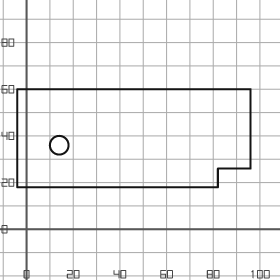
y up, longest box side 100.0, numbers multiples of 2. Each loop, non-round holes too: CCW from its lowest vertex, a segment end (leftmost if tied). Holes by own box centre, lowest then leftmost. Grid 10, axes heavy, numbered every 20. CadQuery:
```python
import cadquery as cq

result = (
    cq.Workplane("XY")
    .moveTo(-4.0, 18.0)
    .lineTo(82.0, 18.0)
    .lineTo(82.0, 26.0)
    .lineTo(96.0, 26.0)
    .lineTo(96.0, 60.0)
    .lineTo(-4.0, 60.0)
    .close()
    .moveTo(14.0, 36.0)
    .circle(4.0)
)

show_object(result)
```